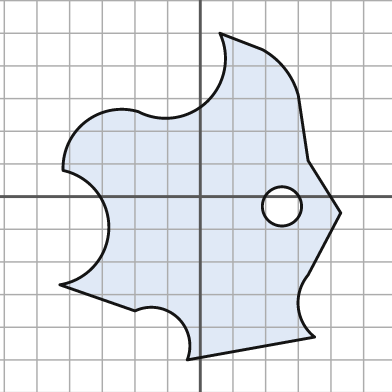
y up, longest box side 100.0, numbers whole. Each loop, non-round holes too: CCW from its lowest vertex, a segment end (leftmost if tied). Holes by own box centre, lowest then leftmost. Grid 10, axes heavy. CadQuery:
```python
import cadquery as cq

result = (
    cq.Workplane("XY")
    .moveTo(-4.0, -50.0)
    .lineTo(35.0, -43.0)
    .threePointArc((30.0, -34.0), (33.0, -24.0))
    .lineTo(43.0, -5.0)
    .lineTo(33.0, 11.0)
    .lineTo(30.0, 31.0)
    .threePointArc((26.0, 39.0), (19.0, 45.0))
    .lineTo(6.0, 50.0)
    .threePointArc((2.0, 29.0), (-19.0, 26.0))
    .threePointArc((-35.0, 23.0), (-42.0, 8.0))
    .threePointArc((-28.0, -10.0), (-43.0, -27.0))
    .lineTo(-20.0, -35.0)
    .threePointArc((-7.0, -37.0), (-4.0, -50.0))
    .close()
    .moveTo(25.0, -3.0)
    .circle(6.0)
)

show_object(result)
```